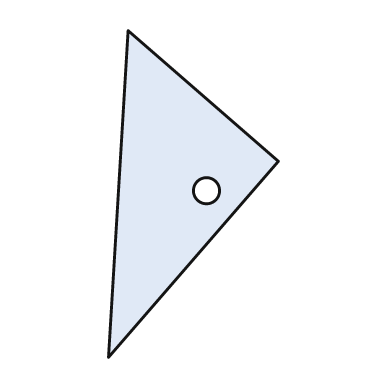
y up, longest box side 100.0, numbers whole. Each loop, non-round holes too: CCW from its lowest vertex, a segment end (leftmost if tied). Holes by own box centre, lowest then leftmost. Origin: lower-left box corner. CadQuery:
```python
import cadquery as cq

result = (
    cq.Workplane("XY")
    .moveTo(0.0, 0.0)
    .lineTo(52.0, 60.0)
    .lineTo(6.0, 100.0)
    .close()
    .moveTo(30.0, 51.0)
    .circle(4.0)
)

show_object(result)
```